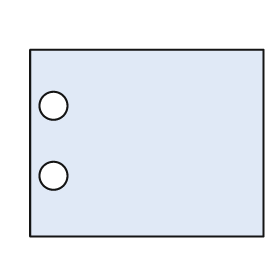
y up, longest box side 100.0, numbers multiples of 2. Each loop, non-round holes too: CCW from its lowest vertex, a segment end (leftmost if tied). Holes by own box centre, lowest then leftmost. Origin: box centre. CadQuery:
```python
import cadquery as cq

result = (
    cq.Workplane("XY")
    .moveTo(-50.0, -40.0)
    .lineTo(50.0, -40.0)
    .lineTo(50.0, 40.0)
    .lineTo(-50.0, 40.0)
    .close()
    .moveTo(-40.0, -14.0)
    .circle(6.0)
    .moveTo(-40.0, 16.0)
    .circle(6.0)
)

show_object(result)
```